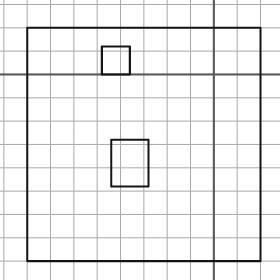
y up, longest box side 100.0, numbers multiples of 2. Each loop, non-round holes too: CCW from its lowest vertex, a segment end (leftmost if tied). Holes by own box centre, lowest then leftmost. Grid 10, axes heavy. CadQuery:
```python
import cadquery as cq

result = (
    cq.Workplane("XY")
    .moveTo(-80.0, -80.0)
    .lineTo(20.0, -80.0)
    .lineTo(20.0, 20.0)
    .lineTo(-80.0, 20.0)
    .close()
    .moveTo(-44.0, -48.0)
    .lineTo(-28.0, -48.0)
    .lineTo(-28.0, -28.0)
    .lineTo(-44.0, -28.0)
    .close()
    .moveTo(-48.0, 0.0)
    .lineTo(-36.0, 0.0)
    .lineTo(-36.0, 12.0)
    .lineTo(-48.0, 12.0)
    .close()
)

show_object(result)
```